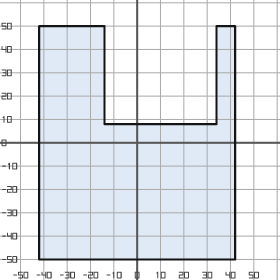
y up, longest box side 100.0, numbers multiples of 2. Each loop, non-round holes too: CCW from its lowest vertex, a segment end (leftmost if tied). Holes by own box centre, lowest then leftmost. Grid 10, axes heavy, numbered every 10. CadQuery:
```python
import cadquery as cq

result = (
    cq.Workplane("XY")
    .moveTo(-42.0, -50.0)
    .lineTo(42.0, -50.0)
    .lineTo(42.0, 50.0)
    .lineTo(34.0, 50.0)
    .lineTo(34.0, 8.0)
    .lineTo(-14.0, 8.0)
    .lineTo(-14.0, 50.0)
    .lineTo(-42.0, 50.0)
    .close()
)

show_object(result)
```